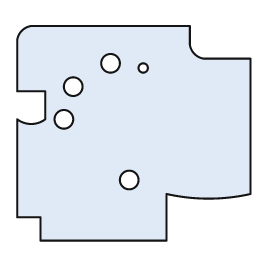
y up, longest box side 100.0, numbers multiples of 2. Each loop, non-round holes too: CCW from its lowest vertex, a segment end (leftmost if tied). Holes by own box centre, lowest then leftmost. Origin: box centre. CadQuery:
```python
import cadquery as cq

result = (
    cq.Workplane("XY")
    .moveTo(-40.0, -46.0)
    .lineTo(14.0, -46.0)
    .lineTo(14.0, -26.0)
    .threePointArc((32.0, -28.0), (50.0, -26.0))
    .lineTo(50.0, 32.0)
    .lineTo(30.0, 32.0)
    .threePointArc((26.0, 34.0), (24.0, 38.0))
    .lineTo(24.0, 46.0)
    .lineTo(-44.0, 46.0)
    .threePointArc((-48.0, 44.0), (-50.0, 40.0))
    .lineTo(-50.0, 18.0)
    .lineTo(-38.0, 18.0)
    .lineTo(-38.0, 6.0)
    .threePointArc((-44.0, 4.0), (-50.0, 6.0))
    .lineTo(-50.0, -36.0)
    .lineTo(-40.0, -36.0)
    .close()
    .moveTo(-2.0, -20.0)
    .circle(4.0)
    .moveTo(-30.0, 6.0)
    .circle(4.0)
    .moveTo(-26.0, 20.0)
    .circle(4.0)
    .moveTo(4.0, 28.0)
    .circle(2.0)
    .moveTo(-10.0, 30.0)
    .circle(4.0)
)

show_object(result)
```